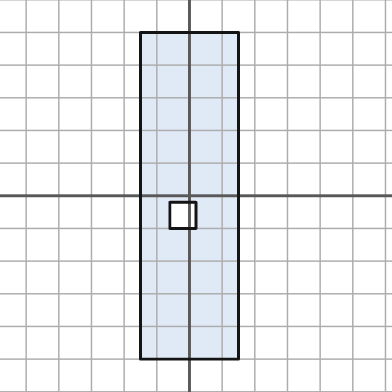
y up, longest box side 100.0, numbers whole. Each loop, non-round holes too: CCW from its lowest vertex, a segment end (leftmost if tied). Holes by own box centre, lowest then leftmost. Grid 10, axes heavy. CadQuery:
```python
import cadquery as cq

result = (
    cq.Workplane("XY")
    .moveTo(-15.0, -50.0)
    .lineTo(15.0, -50.0)
    .lineTo(15.0, 50.0)
    .lineTo(-15.0, 50.0)
    .close()
    .moveTo(-6.0, -10.0)
    .lineTo(2.0, -10.0)
    .lineTo(2.0, -2.0)
    .lineTo(-6.0, -2.0)
    .close()
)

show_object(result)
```